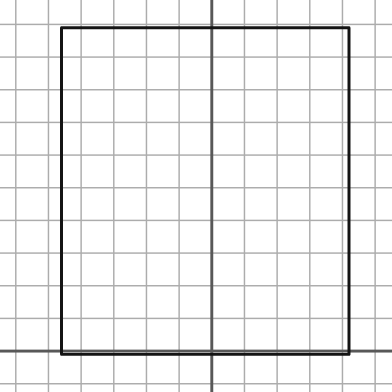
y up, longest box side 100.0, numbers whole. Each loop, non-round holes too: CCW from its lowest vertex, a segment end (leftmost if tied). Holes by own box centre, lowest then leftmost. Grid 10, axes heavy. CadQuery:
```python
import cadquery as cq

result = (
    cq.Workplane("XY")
    .moveTo(-46.0, -1.0)
    .lineTo(42.0, -1.0)
    .lineTo(42.0, 99.0)
    .lineTo(-46.0, 99.0)
    .close()
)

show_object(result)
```